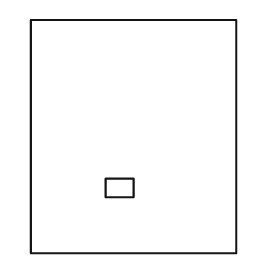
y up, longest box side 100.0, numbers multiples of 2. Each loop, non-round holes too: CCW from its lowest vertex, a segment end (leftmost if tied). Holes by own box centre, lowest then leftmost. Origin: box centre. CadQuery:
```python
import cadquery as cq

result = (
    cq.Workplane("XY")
    .moveTo(-44.0, -50.0)
    .lineTo(44.0, -50.0)
    .lineTo(44.0, 50.0)
    .lineTo(-44.0, 50.0)
    .close()
    .moveTo(-12.0, -26.0)
    .lineTo(0.0, -26.0)
    .lineTo(0.0, -18.0)
    .lineTo(-12.0, -18.0)
    .close()
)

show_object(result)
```